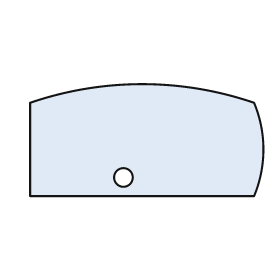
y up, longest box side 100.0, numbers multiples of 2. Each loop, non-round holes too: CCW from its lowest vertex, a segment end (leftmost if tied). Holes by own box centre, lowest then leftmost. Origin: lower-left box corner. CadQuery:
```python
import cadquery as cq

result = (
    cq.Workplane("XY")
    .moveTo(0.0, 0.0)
    .lineTo(96.0, 0.0)
    .threePointArc((100.0, 20.0), (96.0, 40.0))
    .threePointArc((48.0, 48.0), (0.0, 40.0))
    .close()
    .moveTo(40.0, 8.0)
    .circle(4.0)
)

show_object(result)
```